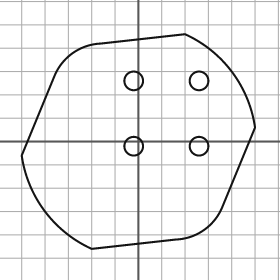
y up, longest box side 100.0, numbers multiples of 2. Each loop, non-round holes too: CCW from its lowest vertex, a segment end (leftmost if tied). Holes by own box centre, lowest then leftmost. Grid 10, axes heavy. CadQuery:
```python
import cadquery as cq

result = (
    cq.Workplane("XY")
    .moveTo(-20.0, -46.0)
    .lineTo(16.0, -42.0)
    .threePointArc((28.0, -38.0), (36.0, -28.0))
    .lineTo(50.0, 6.0)
    .threePointArc((40.0, 30.0), (20.0, 46.0))
    .lineTo(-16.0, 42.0)
    .threePointArc((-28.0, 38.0), (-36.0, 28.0))
    .lineTo(-50.0, -6.0)
    .threePointArc((-40.0, -30.0), (-20.0, -46.0))
    .close()
    .moveTo(-2.0, -2.0)
    .circle(4.0)
    .moveTo(26.0, -2.0)
    .circle(4.0)
    .moveTo(-2.0, 26.0)
    .circle(4.0)
    .moveTo(26.0, 26.0)
    .circle(4.0)
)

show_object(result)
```